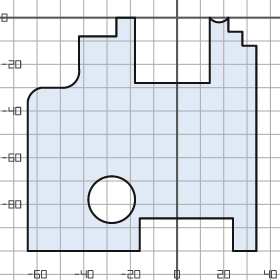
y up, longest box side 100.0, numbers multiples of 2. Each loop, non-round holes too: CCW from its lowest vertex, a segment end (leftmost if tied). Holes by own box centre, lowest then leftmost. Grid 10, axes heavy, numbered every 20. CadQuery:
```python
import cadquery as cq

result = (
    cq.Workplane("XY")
    .moveTo(-64.0, -100.0)
    .lineTo(-16.0, -100.0)
    .lineTo(-16.0, -86.0)
    .lineTo(24.0, -86.0)
    .lineTo(24.0, -100.0)
    .lineTo(34.0, -100.0)
    .lineTo(34.0, -12.0)
    .lineTo(28.0, -12.0)
    .lineTo(28.0, -6.0)
    .lineTo(22.0, -6.0)
    .lineTo(22.0, 0.0)
    .threePointArc((18.0, -2.0), (14.0, 0.0))
    .lineTo(14.0, -28.0)
    .lineTo(-18.0, -28.0)
    .lineTo(-18.0, 0.0)
    .lineTo(-26.0, 0.0)
    .lineTo(-26.0, -8.0)
    .lineTo(-42.0, -8.0)
    .lineTo(-42.0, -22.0)
    .threePointArc((-44.0, -28.0), (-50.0, -30.0))
    .lineTo(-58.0, -30.0)
    .threePointArc((-62.0, -32.0), (-64.0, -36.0))
    .close()
    .moveTo(-28.0, -78.0)
    .circle(10.0)
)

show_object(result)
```